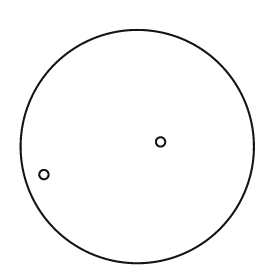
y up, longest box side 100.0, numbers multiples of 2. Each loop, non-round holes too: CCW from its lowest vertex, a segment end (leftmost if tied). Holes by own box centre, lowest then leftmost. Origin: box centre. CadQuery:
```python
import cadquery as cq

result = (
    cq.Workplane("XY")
    .moveTo(0.0, 0.0)
    .circle(50.0)
    .moveTo(-40.0, -12.0)
    .circle(2.0)
    .moveTo(10.0, 2.0)
    .circle(2.0)
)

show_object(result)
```